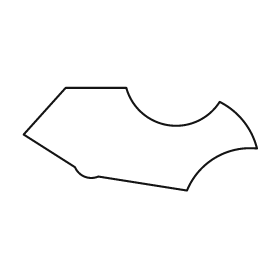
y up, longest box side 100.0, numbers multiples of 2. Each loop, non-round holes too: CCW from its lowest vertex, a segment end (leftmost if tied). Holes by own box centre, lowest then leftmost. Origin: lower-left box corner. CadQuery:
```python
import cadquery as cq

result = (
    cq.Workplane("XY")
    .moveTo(70.0, 0.0)
    .threePointArc((82.0, 14.0), (100.0, 18.0))
    .threePointArc((94.0, 30.0), (84.0, 38.0))
    .threePointArc((62.0, 28.0), (44.0, 44.0))
    .lineTo(18.0, 44.0)
    .lineTo(0.0, 24.0)
    .lineTo(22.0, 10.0)
    .threePointArc((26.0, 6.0), (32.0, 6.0))
    .close()
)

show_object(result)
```